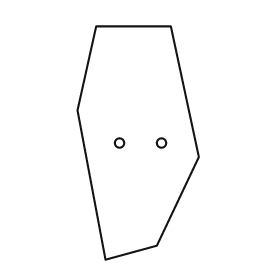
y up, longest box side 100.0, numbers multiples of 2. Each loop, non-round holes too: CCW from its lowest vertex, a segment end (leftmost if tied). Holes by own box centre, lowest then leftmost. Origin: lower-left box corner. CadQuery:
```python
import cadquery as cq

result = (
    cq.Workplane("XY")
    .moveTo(12.0, 0.0)
    .lineTo(34.0, 6.0)
    .lineTo(52.0, 44.0)
    .lineTo(40.0, 100.0)
    .lineTo(8.0, 100.0)
    .lineTo(0.0, 64.0)
    .close()
    .moveTo(18.0, 50.0)
    .circle(2.0)
    .moveTo(36.0, 50.0)
    .circle(2.0)
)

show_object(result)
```